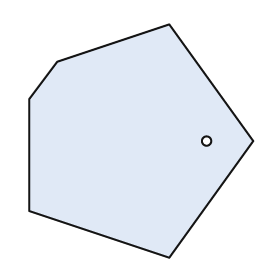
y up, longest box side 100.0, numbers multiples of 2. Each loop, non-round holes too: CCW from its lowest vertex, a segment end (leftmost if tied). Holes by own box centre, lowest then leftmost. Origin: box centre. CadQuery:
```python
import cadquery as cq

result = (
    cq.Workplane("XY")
    .moveTo(12.0, -50.0)
    .lineTo(48.0, 0.0)
    .lineTo(12.0, 50.0)
    .lineTo(-36.0, 34.0)
    .lineTo(-48.0, 18.0)
    .lineTo(-48.0, -30.0)
    .close()
    .moveTo(28.0, 0.0)
    .circle(2.0)
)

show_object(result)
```